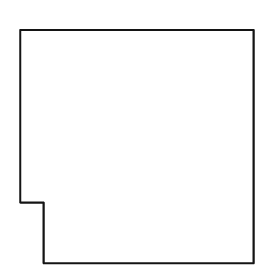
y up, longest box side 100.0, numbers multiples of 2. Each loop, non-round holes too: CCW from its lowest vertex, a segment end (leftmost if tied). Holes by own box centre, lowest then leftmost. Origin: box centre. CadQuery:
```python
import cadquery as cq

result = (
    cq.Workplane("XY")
    .moveTo(-40.0, -50.0)
    .lineTo(50.0, -50.0)
    .lineTo(50.0, 50.0)
    .lineTo(-50.0, 50.0)
    .lineTo(-50.0, -24.0)
    .lineTo(-40.0, -24.0)
    .close()
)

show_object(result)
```